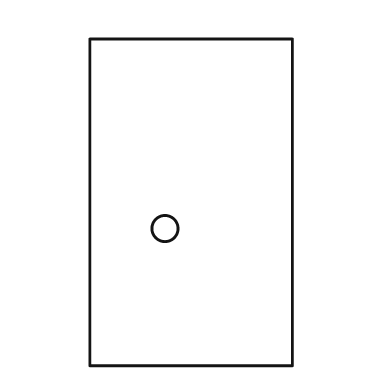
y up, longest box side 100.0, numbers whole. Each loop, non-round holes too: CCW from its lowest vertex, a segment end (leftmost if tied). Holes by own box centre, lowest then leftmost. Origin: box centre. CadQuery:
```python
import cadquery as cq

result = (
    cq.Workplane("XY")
    .moveTo(-31.0, -50.0)
    .lineTo(31.0, -50.0)
    .lineTo(31.0, 50.0)
    .lineTo(-31.0, 50.0)
    .close()
    .moveTo(-8.0, -8.0)
    .circle(4.0)
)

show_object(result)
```